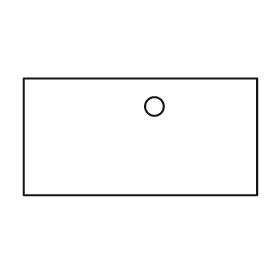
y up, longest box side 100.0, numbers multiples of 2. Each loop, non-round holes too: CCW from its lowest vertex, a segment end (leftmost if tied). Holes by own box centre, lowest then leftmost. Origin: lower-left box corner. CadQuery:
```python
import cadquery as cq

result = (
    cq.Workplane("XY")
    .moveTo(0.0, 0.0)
    .lineTo(100.0, 0.0)
    .lineTo(100.0, 50.0)
    .lineTo(0.0, 50.0)
    .close()
    .moveTo(56.0, 38.0)
    .circle(4.0)
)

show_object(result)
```